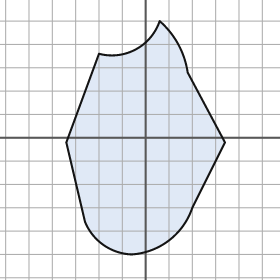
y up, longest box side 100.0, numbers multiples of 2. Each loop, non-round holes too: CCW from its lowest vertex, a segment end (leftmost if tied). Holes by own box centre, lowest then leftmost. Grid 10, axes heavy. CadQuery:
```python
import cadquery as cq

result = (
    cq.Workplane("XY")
    .moveTo(-6.0, -50.0)
    .threePointArc((10.0, -44.0), (20.0, -30.0))
    .lineTo(34.0, -2.0)
    .lineTo(18.0, 28.0)
    .threePointArc((14.0, 40.0), (6.0, 50.0))
    .threePointArc((-4.0, 38.0), (-20.0, 36.0))
    .lineTo(-34.0, -2.0)
    .lineTo(-26.0, -36.0)
    .threePointArc((-18.0, -46.0), (-6.0, -50.0))
    .close()
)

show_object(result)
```